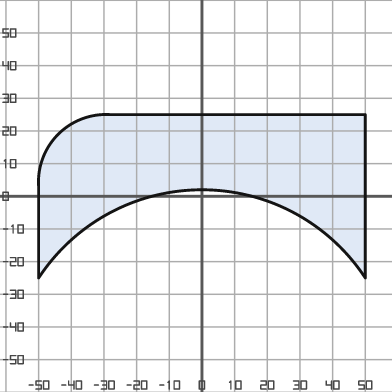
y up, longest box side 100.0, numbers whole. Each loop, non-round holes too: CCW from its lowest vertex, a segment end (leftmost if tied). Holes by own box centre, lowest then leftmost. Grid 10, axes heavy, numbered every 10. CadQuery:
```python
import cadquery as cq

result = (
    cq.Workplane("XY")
    .moveTo(-50.0, -25.0)
    .threePointArc((0.0, 2.0), (50.0, -25.0))
    .lineTo(50.0, 25.0)
    .lineTo(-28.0, 25.0)
    .threePointArc((-44.0, 19.0), (-50.0, 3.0))
    .close()
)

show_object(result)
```